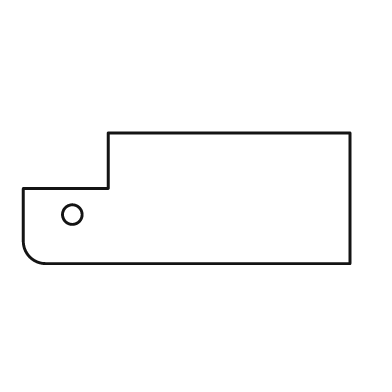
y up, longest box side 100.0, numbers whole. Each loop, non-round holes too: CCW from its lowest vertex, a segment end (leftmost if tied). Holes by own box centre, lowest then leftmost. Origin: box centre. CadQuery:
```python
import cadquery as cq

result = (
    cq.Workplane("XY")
    .moveTo(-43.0, -20.0)
    .lineTo(50.0, -20.0)
    .lineTo(50.0, 20.0)
    .lineTo(-24.0, 20.0)
    .lineTo(-24.0, 3.0)
    .lineTo(-50.0, 3.0)
    .lineTo(-50.0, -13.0)
    .threePointArc((-48.0, -18.0), (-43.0, -20.0))
    .close()
    .moveTo(-35.0, -5.0)
    .circle(3.0)
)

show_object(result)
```